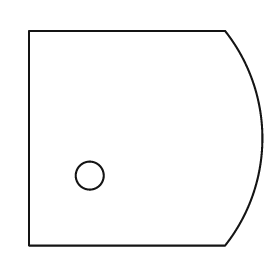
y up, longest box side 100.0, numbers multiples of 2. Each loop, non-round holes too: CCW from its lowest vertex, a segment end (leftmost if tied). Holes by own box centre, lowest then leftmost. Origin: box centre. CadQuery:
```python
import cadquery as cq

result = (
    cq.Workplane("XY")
    .moveTo(-50.0, -46.0)
    .lineTo(34.0, -46.0)
    .threePointArc((50.0, 0.0), (34.0, 46.0))
    .lineTo(-50.0, 46.0)
    .close()
    .moveTo(-24.0, -16.0)
    .circle(6.0)
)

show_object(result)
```